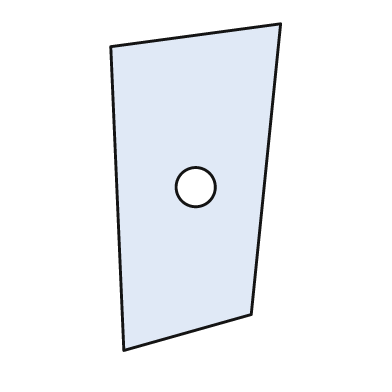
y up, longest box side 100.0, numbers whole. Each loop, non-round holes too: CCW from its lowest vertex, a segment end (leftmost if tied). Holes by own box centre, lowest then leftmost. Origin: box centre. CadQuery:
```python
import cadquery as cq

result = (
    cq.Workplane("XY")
    .moveTo(-22.0, -50.0)
    .lineTo(17.0, -39.0)
    .lineTo(26.0, 50.0)
    .lineTo(-26.0, 43.0)
    .close()
    .moveTo(0.0, 0.0)
    .circle(6.0)
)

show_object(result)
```